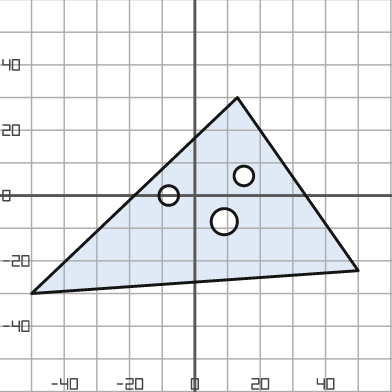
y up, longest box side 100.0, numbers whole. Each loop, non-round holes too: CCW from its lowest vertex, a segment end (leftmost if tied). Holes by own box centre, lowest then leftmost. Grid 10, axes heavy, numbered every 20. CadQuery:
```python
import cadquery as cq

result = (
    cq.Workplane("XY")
    .moveTo(-50.0, -30.0)
    .lineTo(50.0, -23.0)
    .lineTo(13.0, 30.0)
    .close()
    .moveTo(9.0, -8.0)
    .circle(4.0)
    .moveTo(-8.0, 0.0)
    .circle(3.0)
    .moveTo(15.0, 6.0)
    .circle(3.0)
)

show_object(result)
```